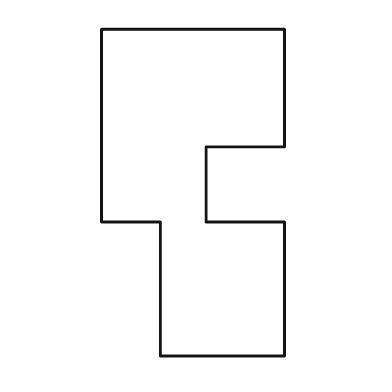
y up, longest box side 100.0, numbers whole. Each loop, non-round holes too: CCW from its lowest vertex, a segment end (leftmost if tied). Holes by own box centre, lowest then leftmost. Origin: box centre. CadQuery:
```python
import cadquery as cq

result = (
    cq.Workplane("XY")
    .moveTo(-10.0, -50.0)
    .lineTo(28.0, -50.0)
    .lineTo(28.0, -9.0)
    .lineTo(4.0, -9.0)
    .lineTo(4.0, 14.0)
    .lineTo(28.0, 14.0)
    .lineTo(28.0, 50.0)
    .lineTo(-28.0, 50.0)
    .lineTo(-28.0, -9.0)
    .lineTo(-10.0, -9.0)
    .close()
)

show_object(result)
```